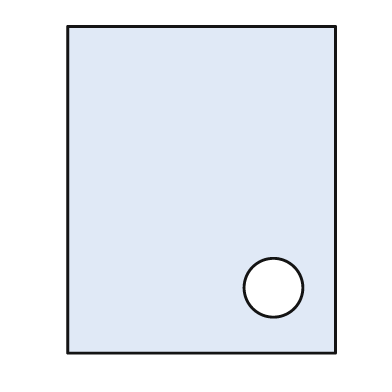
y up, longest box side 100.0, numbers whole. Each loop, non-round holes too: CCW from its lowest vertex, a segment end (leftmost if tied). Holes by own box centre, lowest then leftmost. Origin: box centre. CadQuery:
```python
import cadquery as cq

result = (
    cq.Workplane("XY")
    .moveTo(-41.0, -50.0)
    .lineTo(41.0, -50.0)
    .lineTo(41.0, 50.0)
    .lineTo(-41.0, 50.0)
    .close()
    .moveTo(22.0, -30.0)
    .circle(9.0)
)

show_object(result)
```